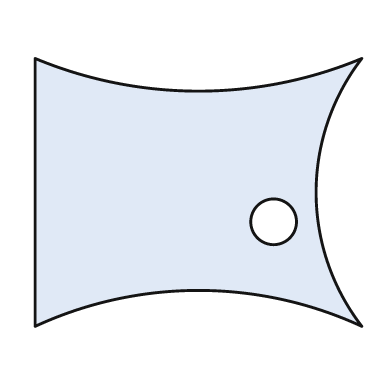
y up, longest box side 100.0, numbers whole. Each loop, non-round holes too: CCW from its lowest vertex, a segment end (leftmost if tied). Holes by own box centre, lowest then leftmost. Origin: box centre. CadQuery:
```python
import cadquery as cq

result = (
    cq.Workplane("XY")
    .moveTo(-50.0, -41.0)
    .threePointArc((0.0, -30.0), (50.0, -41.0))
    .threePointArc((36.0, 0.0), (50.0, 41.0))
    .threePointArc((0.0, 31.0), (-50.0, 41.0))
    .close()
    .moveTo(23.0, -9.0)
    .circle(7.0)
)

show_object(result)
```